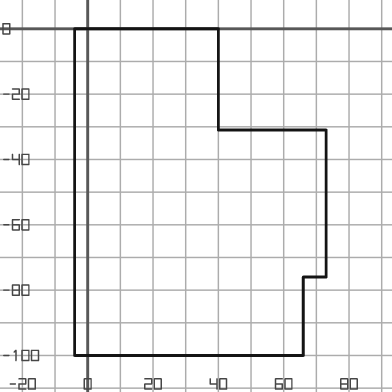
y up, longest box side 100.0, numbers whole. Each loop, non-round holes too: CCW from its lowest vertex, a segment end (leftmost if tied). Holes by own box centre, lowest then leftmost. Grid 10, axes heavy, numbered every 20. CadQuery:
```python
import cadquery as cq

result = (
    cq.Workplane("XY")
    .moveTo(-4.0, -100.0)
    .lineTo(66.0, -100.0)
    .lineTo(66.0, -76.0)
    .lineTo(73.0, -76.0)
    .lineTo(73.0, -31.0)
    .lineTo(40.0, -31.0)
    .lineTo(40.0, 0.0)
    .lineTo(-4.0, 0.0)
    .close()
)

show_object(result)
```